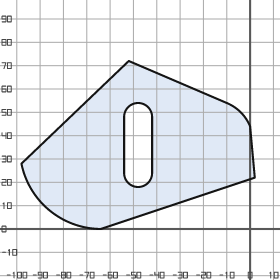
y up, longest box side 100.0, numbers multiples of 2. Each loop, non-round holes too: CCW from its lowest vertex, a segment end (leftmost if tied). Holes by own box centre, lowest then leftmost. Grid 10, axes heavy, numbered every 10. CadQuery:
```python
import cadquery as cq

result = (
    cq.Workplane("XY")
    .moveTo(-64.0, 0.0)
    .lineTo(2.0, 22.0)
    .lineTo(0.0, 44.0)
    .threePointArc((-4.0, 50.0), (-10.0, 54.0))
    .lineTo(-52.0, 72.0)
    .lineTo(-98.0, 28.0)
    .threePointArc((-86.0, 8.0), (-64.0, 0.0))
    .close()
    .moveTo(-54.0, 24.0)
    .threePointArc((-48.0, 18.0), (-42.0, 24.0))
    .lineTo(-42.0, 48.0)
    .threePointArc((-48.0, 54.0), (-54.0, 48.0))
    .close()
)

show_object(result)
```